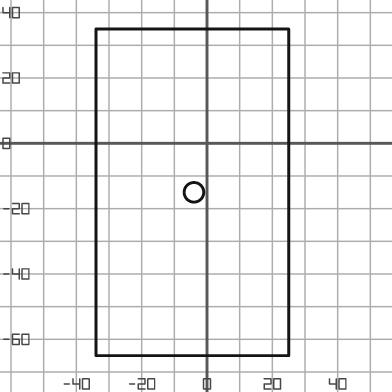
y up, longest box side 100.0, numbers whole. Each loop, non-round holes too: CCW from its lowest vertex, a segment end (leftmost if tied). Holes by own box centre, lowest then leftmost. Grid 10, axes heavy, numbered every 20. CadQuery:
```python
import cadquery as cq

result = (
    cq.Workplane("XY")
    .moveTo(-34.0, -65.0)
    .lineTo(25.0, -65.0)
    .lineTo(25.0, 35.0)
    .lineTo(-34.0, 35.0)
    .close()
    .moveTo(-4.0, -15.0)
    .circle(3.0)
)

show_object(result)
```